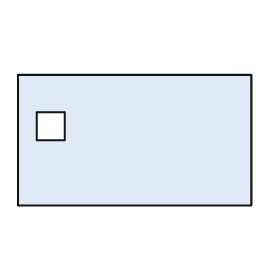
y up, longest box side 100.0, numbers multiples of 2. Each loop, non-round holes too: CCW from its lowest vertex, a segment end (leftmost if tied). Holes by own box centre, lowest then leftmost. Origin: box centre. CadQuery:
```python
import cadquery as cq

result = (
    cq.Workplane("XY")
    .moveTo(-50.0, -28.0)
    .lineTo(50.0, -28.0)
    .lineTo(50.0, 28.0)
    .lineTo(-50.0, 28.0)
    .close()
    .moveTo(-42.0, 0.0)
    .lineTo(-30.0, 0.0)
    .lineTo(-30.0, 12.0)
    .lineTo(-42.0, 12.0)
    .close()
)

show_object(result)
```